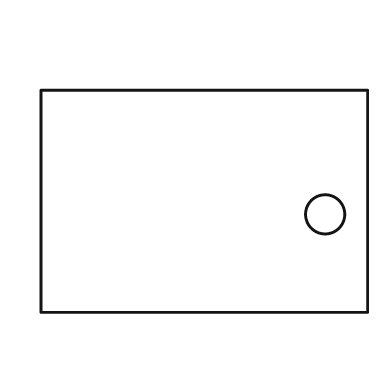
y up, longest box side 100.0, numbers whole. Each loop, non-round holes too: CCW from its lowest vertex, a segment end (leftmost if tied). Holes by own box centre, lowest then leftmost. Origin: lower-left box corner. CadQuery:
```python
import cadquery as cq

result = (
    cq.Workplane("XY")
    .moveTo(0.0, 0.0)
    .lineTo(100.0, 0.0)
    .lineTo(100.0, 68.0)
    .lineTo(0.0, 68.0)
    .close()
    .moveTo(87.0, 30.0)
    .circle(6.0)
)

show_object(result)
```